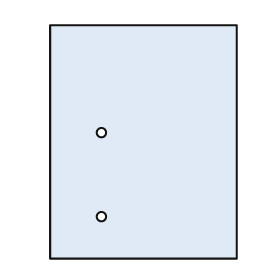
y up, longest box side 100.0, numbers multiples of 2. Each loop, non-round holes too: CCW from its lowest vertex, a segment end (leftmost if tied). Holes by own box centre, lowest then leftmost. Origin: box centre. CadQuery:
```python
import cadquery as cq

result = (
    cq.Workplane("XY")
    .moveTo(-40.0, -50.0)
    .lineTo(40.0, -50.0)
    .lineTo(40.0, 50.0)
    .lineTo(-40.0, 50.0)
    .close()
    .moveTo(-18.0, -32.0)
    .circle(2.0)
    .moveTo(-18.0, 4.0)
    .circle(2.0)
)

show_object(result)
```